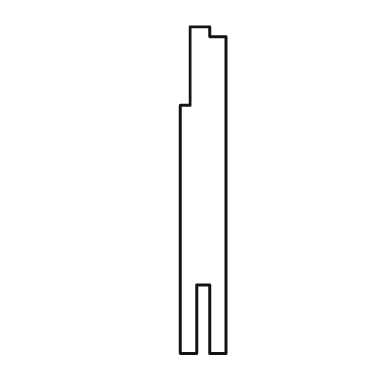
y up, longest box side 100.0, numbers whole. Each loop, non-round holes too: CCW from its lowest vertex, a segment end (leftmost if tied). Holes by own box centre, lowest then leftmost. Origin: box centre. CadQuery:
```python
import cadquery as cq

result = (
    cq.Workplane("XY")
    .moveTo(-7.0, -50.0)
    .lineTo(-2.0, -50.0)
    .lineTo(-2.0, -29.0)
    .lineTo(2.0, -29.0)
    .lineTo(2.0, -50.0)
    .lineTo(7.0, -50.0)
    .lineTo(7.0, 47.0)
    .lineTo(2.0, 47.0)
    .lineTo(2.0, 50.0)
    .lineTo(-4.0, 50.0)
    .lineTo(-4.0, 26.0)
    .lineTo(-7.0, 26.0)
    .close()
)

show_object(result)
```